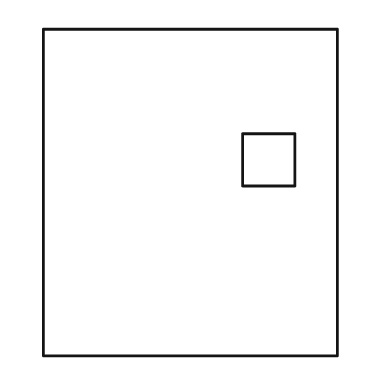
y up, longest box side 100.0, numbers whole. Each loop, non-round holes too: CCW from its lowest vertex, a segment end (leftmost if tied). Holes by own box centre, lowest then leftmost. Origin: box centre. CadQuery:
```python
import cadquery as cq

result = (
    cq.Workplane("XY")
    .moveTo(-45.0, -50.0)
    .lineTo(45.0, -50.0)
    .lineTo(45.0, 50.0)
    .lineTo(-45.0, 50.0)
    .close()
    .moveTo(16.0, 2.0)
    .lineTo(32.0, 2.0)
    .lineTo(32.0, 18.0)
    .lineTo(16.0, 18.0)
    .close()
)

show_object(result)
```